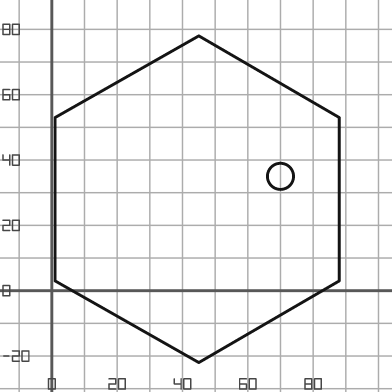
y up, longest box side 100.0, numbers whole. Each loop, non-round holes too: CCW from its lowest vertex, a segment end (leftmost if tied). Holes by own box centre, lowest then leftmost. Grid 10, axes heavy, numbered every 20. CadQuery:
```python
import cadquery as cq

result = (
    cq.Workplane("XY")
    .moveTo(45.0, -22.0)
    .lineTo(88.0, 3.0)
    .lineTo(88.0, 53.0)
    .lineTo(45.0, 78.0)
    .lineTo(1.0, 53.0)
    .lineTo(1.0, 3.0)
    .close()
    .moveTo(70.0, 35.0)
    .circle(4.0)
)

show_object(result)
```